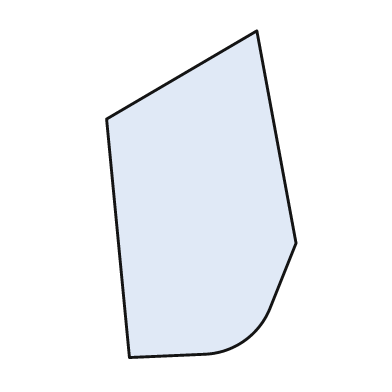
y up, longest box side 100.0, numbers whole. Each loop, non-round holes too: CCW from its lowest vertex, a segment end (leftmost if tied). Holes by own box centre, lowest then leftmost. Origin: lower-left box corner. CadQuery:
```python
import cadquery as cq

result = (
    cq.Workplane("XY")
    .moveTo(7.0, 0.0)
    .lineTo(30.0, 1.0)
    .threePointArc((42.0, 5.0), (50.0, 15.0))
    .lineTo(58.0, 35.0)
    .lineTo(46.0, 100.0)
    .lineTo(0.0, 73.0)
    .close()
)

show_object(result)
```